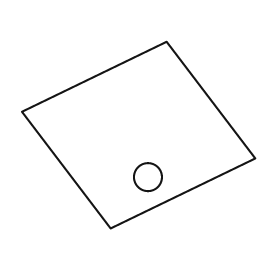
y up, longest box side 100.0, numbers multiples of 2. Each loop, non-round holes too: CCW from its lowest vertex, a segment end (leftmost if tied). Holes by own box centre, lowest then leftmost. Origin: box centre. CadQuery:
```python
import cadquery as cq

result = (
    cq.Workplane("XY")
    .moveTo(-12.0, -40.0)
    .lineTo(50.0, -10.0)
    .lineTo(12.0, 40.0)
    .lineTo(-50.0, 10.0)
    .close()
    .moveTo(4.0, -18.0)
    .circle(6.0)
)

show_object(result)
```